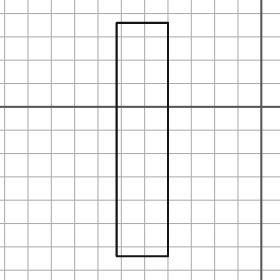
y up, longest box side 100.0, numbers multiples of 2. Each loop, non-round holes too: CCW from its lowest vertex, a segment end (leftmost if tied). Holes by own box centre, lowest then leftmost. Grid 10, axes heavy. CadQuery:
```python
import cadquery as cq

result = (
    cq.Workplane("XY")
    .moveTo(-62.0, -64.0)
    .lineTo(-40.0, -64.0)
    .lineTo(-40.0, 36.0)
    .lineTo(-62.0, 36.0)
    .close()
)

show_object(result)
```